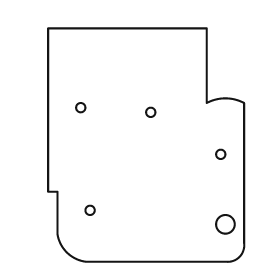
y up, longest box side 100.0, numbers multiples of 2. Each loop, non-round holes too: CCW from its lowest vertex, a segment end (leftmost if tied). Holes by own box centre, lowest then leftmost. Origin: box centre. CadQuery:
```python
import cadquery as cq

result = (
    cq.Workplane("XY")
    .moveTo(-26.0, -50.0)
    .lineTo(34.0, -50.0)
    .threePointArc((40.0, -48.0), (42.0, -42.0))
    .lineTo(42.0, 18.0)
    .threePointArc((34.0, 20.0), (26.0, 18.0))
    .lineTo(26.0, 50.0)
    .lineTo(-42.0, 50.0)
    .lineTo(-42.0, -20.0)
    .lineTo(-38.0, -20.0)
    .lineTo(-38.0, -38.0)
    .threePointArc((-34.0, -46.0), (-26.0, -50.0))
    .close()
    .moveTo(34.0, -34.0)
    .circle(4.0)
    .moveTo(-24.0, -28.0)
    .circle(2.0)
    .moveTo(32.0, -4.0)
    .circle(2.0)
    .moveTo(2.0, 14.0)
    .circle(2.0)
    .moveTo(-28.0, 16.0)
    .circle(2.0)
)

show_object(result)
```